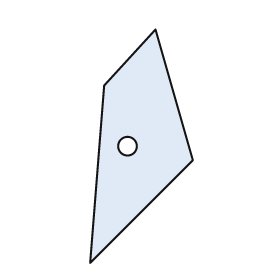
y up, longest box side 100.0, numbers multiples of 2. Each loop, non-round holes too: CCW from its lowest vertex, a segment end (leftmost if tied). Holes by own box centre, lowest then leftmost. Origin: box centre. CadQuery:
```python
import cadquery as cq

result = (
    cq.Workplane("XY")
    .moveTo(-22.0, -50.0)
    .lineTo(22.0, -6.0)
    .lineTo(6.0, 50.0)
    .lineTo(-16.0, 26.0)
    .close()
    .moveTo(-6.0, 0.0)
    .circle(4.0)
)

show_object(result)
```